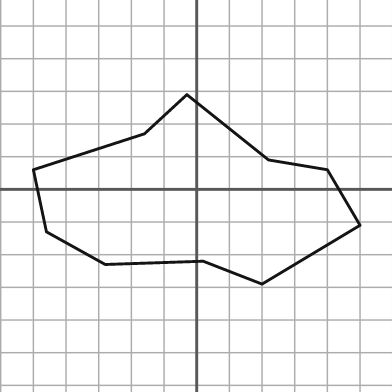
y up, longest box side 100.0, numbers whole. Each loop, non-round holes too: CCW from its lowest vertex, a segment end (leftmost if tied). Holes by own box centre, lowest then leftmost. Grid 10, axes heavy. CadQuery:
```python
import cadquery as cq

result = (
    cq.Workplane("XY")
    .moveTo(20.0, -29.0)
    .lineTo(50.0, -11.0)
    .lineTo(40.0, 6.0)
    .lineTo(22.0, 9.0)
    .lineTo(-3.0, 29.0)
    .lineTo(-16.0, 17.0)
    .lineTo(-50.0, 6.0)
    .lineTo(-46.0, -13.0)
    .lineTo(-28.0, -23.0)
    .lineTo(2.0, -22.0)
    .close()
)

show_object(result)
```